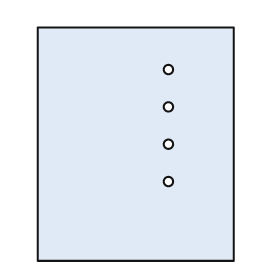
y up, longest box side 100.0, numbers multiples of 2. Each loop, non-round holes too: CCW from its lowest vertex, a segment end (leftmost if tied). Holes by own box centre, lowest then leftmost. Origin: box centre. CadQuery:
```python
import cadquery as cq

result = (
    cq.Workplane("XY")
    .moveTo(-42.0, -50.0)
    .lineTo(42.0, -50.0)
    .lineTo(42.0, 50.0)
    .lineTo(-42.0, 50.0)
    .close()
    .moveTo(14.0, -16.0)
    .circle(2.0)
    .moveTo(14.0, 0.0)
    .circle(2.0)
    .moveTo(14.0, 16.0)
    .circle(2.0)
    .moveTo(14.0, 32.0)
    .circle(2.0)
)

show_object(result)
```